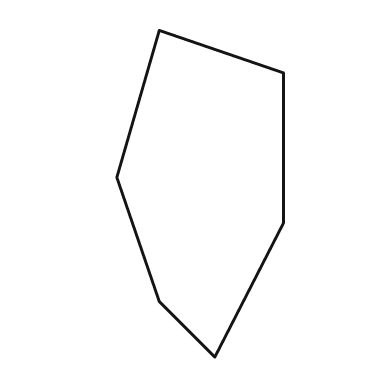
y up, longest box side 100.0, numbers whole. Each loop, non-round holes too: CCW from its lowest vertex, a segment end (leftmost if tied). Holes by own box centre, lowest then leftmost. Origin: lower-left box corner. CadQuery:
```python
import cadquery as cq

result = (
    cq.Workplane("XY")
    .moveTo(30.0, 0.0)
    .lineTo(51.0, 41.0)
    .lineTo(51.0, 87.0)
    .lineTo(13.0, 100.0)
    .lineTo(0.0, 55.0)
    .lineTo(13.0, 17.0)
    .close()
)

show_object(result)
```